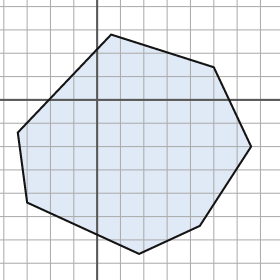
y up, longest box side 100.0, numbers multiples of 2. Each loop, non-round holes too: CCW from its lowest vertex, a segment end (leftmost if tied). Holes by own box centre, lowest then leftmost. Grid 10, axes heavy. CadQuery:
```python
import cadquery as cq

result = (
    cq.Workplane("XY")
    .moveTo(18.0, -66.0)
    .lineTo(44.0, -54.0)
    .lineTo(66.0, -20.0)
    .lineTo(50.0, 14.0)
    .lineTo(6.0, 28.0)
    .lineTo(-34.0, -14.0)
    .lineTo(-30.0, -44.0)
    .close()
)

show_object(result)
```